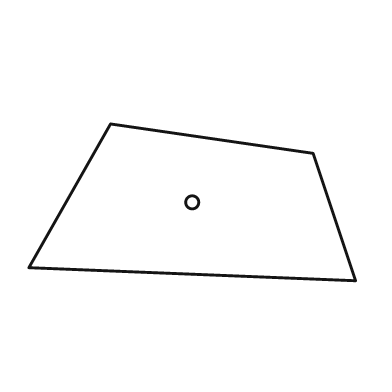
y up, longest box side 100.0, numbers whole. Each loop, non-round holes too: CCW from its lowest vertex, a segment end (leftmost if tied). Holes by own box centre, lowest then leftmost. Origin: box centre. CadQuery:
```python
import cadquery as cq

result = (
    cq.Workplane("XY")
    .moveTo(50.0, -24.0)
    .lineTo(37.0, 15.0)
    .lineTo(-25.0, 24.0)
    .lineTo(-50.0, -20.0)
    .close()
    .moveTo(0.0, 0.0)
    .circle(2.0)
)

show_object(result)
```